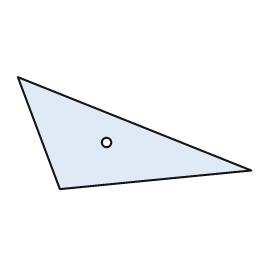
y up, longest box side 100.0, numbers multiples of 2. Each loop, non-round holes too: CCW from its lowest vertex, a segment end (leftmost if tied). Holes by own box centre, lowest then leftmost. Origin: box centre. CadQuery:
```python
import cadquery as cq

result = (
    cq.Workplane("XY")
    .moveTo(-32.0, -24.0)
    .lineTo(50.0, -16.0)
    .lineTo(-50.0, 24.0)
    .close()
    .moveTo(-12.0, -4.0)
    .circle(2.0)
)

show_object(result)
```